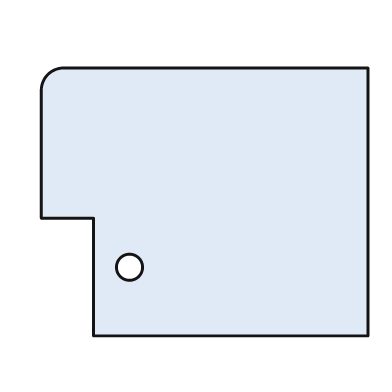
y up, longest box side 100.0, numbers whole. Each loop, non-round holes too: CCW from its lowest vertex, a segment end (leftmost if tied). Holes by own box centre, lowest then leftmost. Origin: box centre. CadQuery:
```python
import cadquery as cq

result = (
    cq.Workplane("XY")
    .moveTo(-34.0, -41.0)
    .lineTo(50.0, -41.0)
    .lineTo(50.0, 41.0)
    .lineTo(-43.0, 41.0)
    .threePointArc((-48.0, 39.0), (-50.0, 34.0))
    .lineTo(-50.0, -5.0)
    .lineTo(-34.0, -5.0)
    .close()
    .moveTo(-23.0, -20.0)
    .circle(4.0)
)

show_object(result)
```